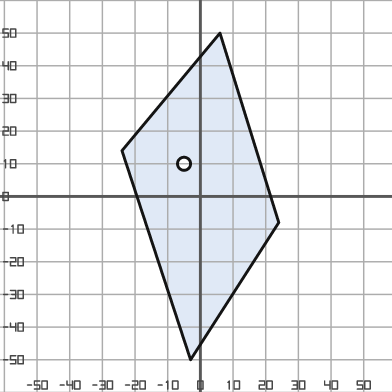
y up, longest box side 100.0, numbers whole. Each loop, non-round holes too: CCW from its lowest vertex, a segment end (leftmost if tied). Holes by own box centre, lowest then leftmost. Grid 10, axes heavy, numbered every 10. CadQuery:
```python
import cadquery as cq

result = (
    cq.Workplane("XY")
    .moveTo(-3.0, -50.0)
    .lineTo(24.0, -8.0)
    .lineTo(6.0, 50.0)
    .lineTo(-24.0, 14.0)
    .close()
    .moveTo(-5.0, 10.0)
    .circle(2.0)
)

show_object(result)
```